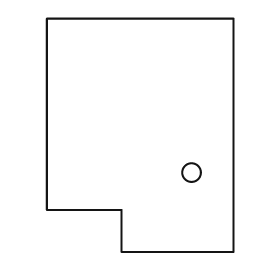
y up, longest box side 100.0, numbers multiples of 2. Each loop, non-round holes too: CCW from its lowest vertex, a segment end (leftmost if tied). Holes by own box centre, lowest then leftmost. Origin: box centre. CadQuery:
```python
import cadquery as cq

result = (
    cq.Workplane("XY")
    .moveTo(-8.0, -50.0)
    .lineTo(40.0, -50.0)
    .lineTo(40.0, 50.0)
    .lineTo(-40.0, 50.0)
    .lineTo(-40.0, -32.0)
    .lineTo(-8.0, -32.0)
    .close()
    .moveTo(22.0, -16.0)
    .circle(4.0)
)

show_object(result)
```